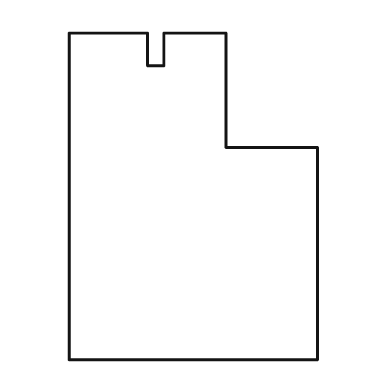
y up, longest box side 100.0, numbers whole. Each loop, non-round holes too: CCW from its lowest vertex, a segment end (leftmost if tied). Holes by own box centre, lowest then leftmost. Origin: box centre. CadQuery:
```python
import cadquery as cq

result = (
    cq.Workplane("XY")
    .moveTo(-38.0, -50.0)
    .lineTo(38.0, -50.0)
    .lineTo(38.0, 15.0)
    .lineTo(10.0, 15.0)
    .lineTo(10.0, 50.0)
    .lineTo(-9.0, 50.0)
    .lineTo(-9.0, 40.0)
    .lineTo(-14.0, 40.0)
    .lineTo(-14.0, 50.0)
    .lineTo(-38.0, 50.0)
    .close()
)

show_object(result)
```